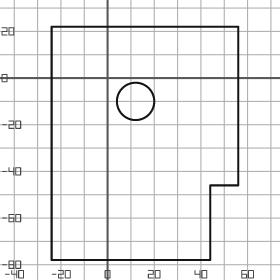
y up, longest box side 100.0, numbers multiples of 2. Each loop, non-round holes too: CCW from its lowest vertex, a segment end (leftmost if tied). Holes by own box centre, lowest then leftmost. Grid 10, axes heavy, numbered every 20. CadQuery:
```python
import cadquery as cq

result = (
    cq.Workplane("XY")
    .moveTo(-24.0, -78.0)
    .lineTo(44.0, -78.0)
    .lineTo(44.0, -46.0)
    .lineTo(56.0, -46.0)
    .lineTo(56.0, 22.0)
    .lineTo(-24.0, 22.0)
    .close()
    .moveTo(12.0, -10.0)
    .circle(8.0)
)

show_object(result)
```